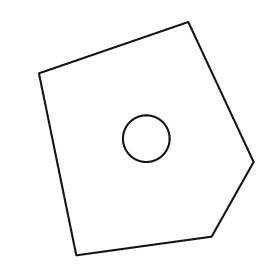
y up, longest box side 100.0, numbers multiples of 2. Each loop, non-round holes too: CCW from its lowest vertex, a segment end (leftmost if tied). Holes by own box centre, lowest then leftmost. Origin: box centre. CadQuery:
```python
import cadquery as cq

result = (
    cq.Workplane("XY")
    .moveTo(-30.0, -50.0)
    .lineTo(28.0, -42.0)
    .lineTo(46.0, -10.0)
    .lineTo(18.0, 50.0)
    .lineTo(-46.0, 28.0)
    .close()
    .moveTo(0.0, 0.0)
    .circle(10.0)
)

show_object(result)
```